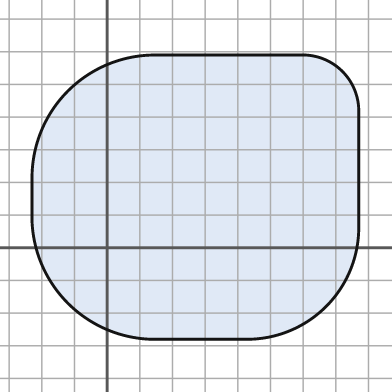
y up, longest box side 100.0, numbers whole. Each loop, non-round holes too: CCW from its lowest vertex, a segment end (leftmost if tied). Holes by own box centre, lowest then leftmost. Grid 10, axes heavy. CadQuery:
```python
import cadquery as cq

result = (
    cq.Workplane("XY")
    .moveTo(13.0, -28.0)
    .lineTo(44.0, -28.0)
    .threePointArc((67.0, -18.0), (77.0, 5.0))
    .lineTo(77.0, 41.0)
    .threePointArc((72.0, 54.0), (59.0, 59.0))
    .lineTo(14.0, 59.0)
    .threePointArc((-12.0, 48.0), (-23.0, 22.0))
    .lineTo(-23.0, 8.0)
    .threePointArc((-12.0, -17.0), (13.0, -28.0))
    .close()
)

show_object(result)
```